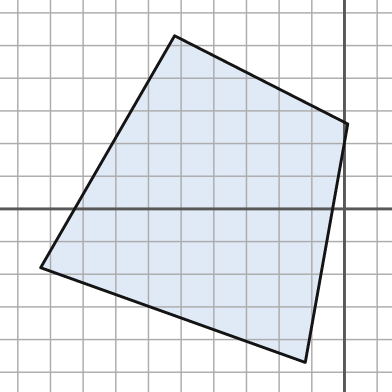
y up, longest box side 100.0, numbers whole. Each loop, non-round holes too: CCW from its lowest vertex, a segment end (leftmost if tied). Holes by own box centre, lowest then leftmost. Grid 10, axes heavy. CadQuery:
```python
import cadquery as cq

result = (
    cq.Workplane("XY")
    .moveTo(-12.0, -47.0)
    .lineTo(1.0, 26.0)
    .lineTo(-52.0, 53.0)
    .lineTo(-93.0, -18.0)
    .close()
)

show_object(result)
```